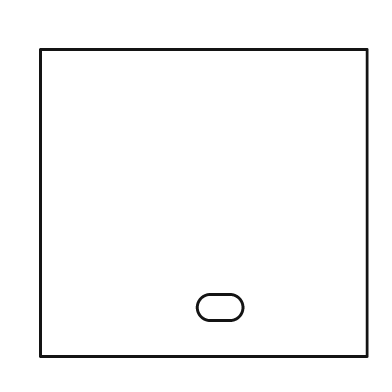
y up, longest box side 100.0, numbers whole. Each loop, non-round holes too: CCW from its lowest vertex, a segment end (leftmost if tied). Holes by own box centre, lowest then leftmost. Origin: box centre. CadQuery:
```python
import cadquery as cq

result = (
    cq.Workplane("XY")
    .moveTo(-50.0, -47.0)
    .lineTo(50.0, -47.0)
    .lineTo(50.0, 47.0)
    .lineTo(-50.0, 47.0)
    .close()
    .moveTo(2.0, -36.0)
    .lineTo(8.0, -36.0)
    .threePointArc((12.0, -32.0), (8.0, -28.0))
    .lineTo(2.0, -28.0)
    .threePointArc((-2.0, -32.0), (2.0, -36.0))
    .close()
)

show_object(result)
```